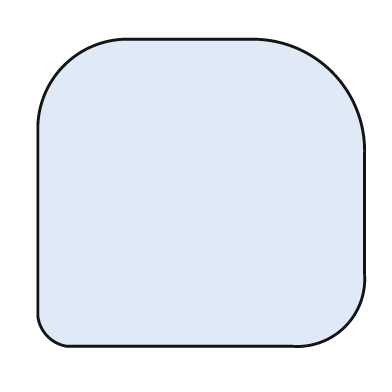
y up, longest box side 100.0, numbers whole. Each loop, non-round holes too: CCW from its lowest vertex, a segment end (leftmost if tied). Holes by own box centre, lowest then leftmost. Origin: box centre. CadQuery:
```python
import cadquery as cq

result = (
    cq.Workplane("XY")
    .moveTo(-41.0, -47.0)
    .lineTo(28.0, -47.0)
    .threePointArc((44.0, -41.0), (50.0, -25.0))
    .lineTo(50.0, 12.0)
    .threePointArc((40.0, 37.0), (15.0, 47.0))
    .lineTo(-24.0, 47.0)
    .threePointArc((-42.0, 39.0), (-50.0, 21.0))
    .lineTo(-50.0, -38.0)
    .threePointArc((-47.0, -44.0), (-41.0, -47.0))
    .close()
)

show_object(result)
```